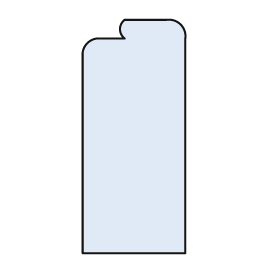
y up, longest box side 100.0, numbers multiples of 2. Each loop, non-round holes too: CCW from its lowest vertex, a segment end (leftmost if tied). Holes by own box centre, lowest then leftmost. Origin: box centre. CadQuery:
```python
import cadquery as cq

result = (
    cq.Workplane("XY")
    .moveTo(-22.0, -50.0)
    .lineTo(22.0, -50.0)
    .lineTo(22.0, 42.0)
    .threePointArc((20.0, 48.0), (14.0, 50.0))
    .lineTo(-4.0, 50.0)
    .threePointArc((-6.0, 46.0), (-4.0, 42.0))
    .lineTo(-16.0, 42.0)
    .threePointArc((-20.0, 40.0), (-22.0, 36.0))
    .close()
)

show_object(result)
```